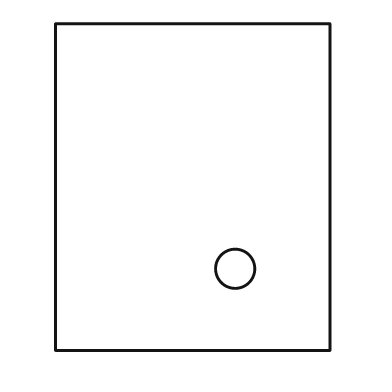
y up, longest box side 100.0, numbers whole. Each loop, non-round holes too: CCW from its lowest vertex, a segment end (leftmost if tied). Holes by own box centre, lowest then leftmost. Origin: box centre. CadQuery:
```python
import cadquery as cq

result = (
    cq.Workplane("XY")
    .moveTo(-42.0, -50.0)
    .lineTo(42.0, -50.0)
    .lineTo(42.0, 50.0)
    .lineTo(-42.0, 50.0)
    .close()
    .moveTo(13.0, -25.0)
    .circle(6.0)
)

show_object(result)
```